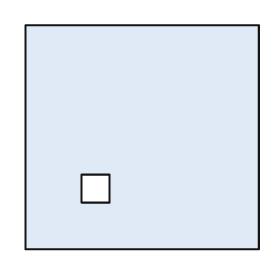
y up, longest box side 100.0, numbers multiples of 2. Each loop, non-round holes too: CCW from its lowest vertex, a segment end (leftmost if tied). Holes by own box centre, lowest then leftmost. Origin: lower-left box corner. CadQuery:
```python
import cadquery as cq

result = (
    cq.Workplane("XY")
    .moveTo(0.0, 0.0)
    .lineTo(100.0, 0.0)
    .lineTo(100.0, 96.0)
    .lineTo(0.0, 96.0)
    .close()
    .moveTo(24.0, 20.0)
    .lineTo(36.0, 20.0)
    .lineTo(36.0, 32.0)
    .lineTo(24.0, 32.0)
    .close()
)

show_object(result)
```